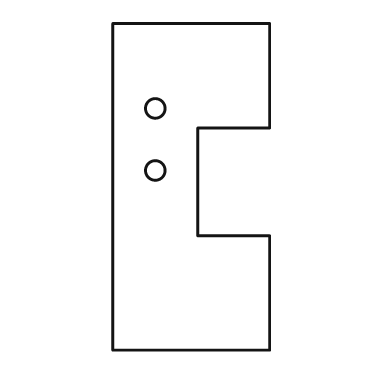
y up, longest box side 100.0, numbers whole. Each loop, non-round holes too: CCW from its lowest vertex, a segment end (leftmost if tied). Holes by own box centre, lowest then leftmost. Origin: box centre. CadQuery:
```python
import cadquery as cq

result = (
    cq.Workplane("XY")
    .moveTo(-24.0, -50.0)
    .lineTo(24.0, -50.0)
    .lineTo(24.0, -15.0)
    .lineTo(2.0, -15.0)
    .lineTo(2.0, 18.0)
    .lineTo(24.0, 18.0)
    .lineTo(24.0, 50.0)
    .lineTo(-24.0, 50.0)
    .close()
    .moveTo(-11.0, 5.0)
    .circle(3.0)
    .moveTo(-11.0, 24.0)
    .circle(3.0)
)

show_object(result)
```